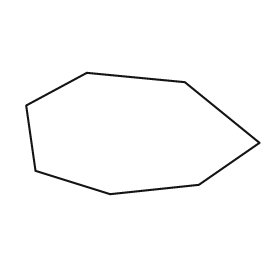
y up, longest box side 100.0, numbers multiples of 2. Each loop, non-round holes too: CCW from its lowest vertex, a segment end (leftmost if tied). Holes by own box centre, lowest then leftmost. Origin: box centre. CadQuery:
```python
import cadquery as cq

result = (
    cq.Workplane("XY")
    .moveTo(-14.0, -26.0)
    .lineTo(24.0, -22.0)
    .lineTo(50.0, -4.0)
    .lineTo(18.0, 22.0)
    .lineTo(-24.0, 26.0)
    .lineTo(-50.0, 12.0)
    .lineTo(-46.0, -16.0)
    .close()
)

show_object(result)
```